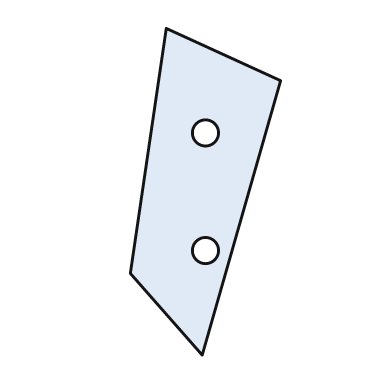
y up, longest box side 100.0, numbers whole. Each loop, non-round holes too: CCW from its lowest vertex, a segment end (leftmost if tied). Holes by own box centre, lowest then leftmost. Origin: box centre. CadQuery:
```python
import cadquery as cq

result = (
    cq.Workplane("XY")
    .moveTo(-1.0, -50.0)
    .lineTo(23.0, 34.0)
    .lineTo(-12.0, 50.0)
    .lineTo(-23.0, -25.0)
    .close()
    .moveTo(0.0, -18.0)
    .circle(4.0)
    .moveTo(0.0, 18.0)
    .circle(4.0)
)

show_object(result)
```